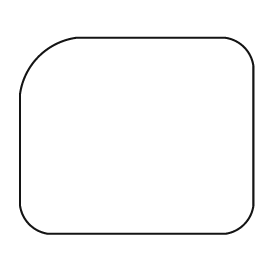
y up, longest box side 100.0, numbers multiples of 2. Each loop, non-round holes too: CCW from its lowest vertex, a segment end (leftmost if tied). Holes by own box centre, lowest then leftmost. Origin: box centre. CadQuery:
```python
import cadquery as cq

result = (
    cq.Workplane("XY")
    .moveTo(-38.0, -42.0)
    .lineTo(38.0, -42.0)
    .threePointArc((46.0, -38.0), (50.0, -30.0))
    .lineTo(50.0, 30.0)
    .threePointArc((46.0, 38.0), (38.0, 42.0))
    .lineTo(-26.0, 42.0)
    .threePointArc((-42.0, 34.0), (-50.0, 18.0))
    .lineTo(-50.0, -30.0)
    .threePointArc((-46.0, -38.0), (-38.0, -42.0))
    .close()
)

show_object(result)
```